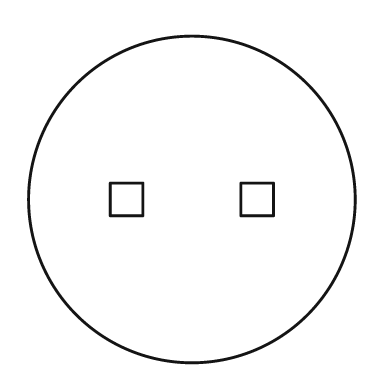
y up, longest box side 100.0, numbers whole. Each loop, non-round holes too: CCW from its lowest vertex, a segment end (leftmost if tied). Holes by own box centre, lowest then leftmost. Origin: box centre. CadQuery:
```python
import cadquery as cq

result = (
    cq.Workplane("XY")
    .moveTo(0.0, 0.0)
    .circle(50.0)
    .moveTo(-25.0, -5.0)
    .lineTo(-15.0, -5.0)
    .lineTo(-15.0, 5.0)
    .lineTo(-25.0, 5.0)
    .close()
    .moveTo(15.0, -5.0)
    .lineTo(25.0, -5.0)
    .lineTo(25.0, 5.0)
    .lineTo(15.0, 5.0)
    .close()
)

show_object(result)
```